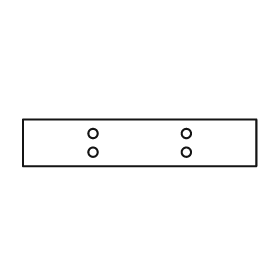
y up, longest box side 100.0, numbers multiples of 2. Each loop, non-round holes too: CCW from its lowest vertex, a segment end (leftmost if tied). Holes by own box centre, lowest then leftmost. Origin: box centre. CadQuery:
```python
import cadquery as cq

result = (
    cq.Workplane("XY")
    .moveTo(-50.0, -10.0)
    .lineTo(50.0, -10.0)
    .lineTo(50.0, 10.0)
    .lineTo(-50.0, 10.0)
    .close()
    .moveTo(-20.0, -4.0)
    .circle(2.0)
    .moveTo(20.0, -4.0)
    .circle(2.0)
    .moveTo(-20.0, 4.0)
    .circle(2.0)
    .moveTo(20.0, 4.0)
    .circle(2.0)
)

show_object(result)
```